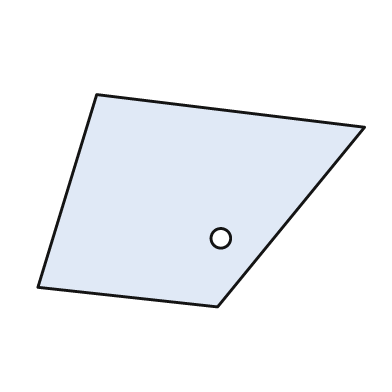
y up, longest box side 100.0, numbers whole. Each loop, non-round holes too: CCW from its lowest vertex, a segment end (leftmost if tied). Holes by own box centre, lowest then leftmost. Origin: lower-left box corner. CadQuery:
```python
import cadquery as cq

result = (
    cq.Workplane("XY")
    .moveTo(55.0, 0.0)
    .lineTo(100.0, 55.0)
    .lineTo(18.0, 65.0)
    .lineTo(0.0, 6.0)
    .close()
    .moveTo(56.0, 21.0)
    .circle(3.0)
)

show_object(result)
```